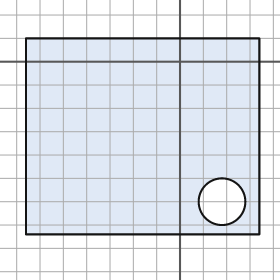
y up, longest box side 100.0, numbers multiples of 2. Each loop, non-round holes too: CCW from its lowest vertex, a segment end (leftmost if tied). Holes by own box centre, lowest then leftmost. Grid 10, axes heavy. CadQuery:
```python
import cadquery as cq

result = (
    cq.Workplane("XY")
    .moveTo(-66.0, -74.0)
    .lineTo(34.0, -74.0)
    .lineTo(34.0, 10.0)
    .lineTo(-66.0, 10.0)
    .close()
    .moveTo(18.0, -60.0)
    .circle(10.0)
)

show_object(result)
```